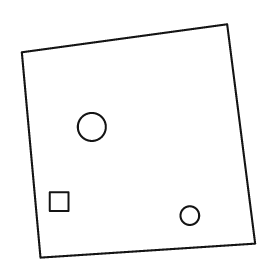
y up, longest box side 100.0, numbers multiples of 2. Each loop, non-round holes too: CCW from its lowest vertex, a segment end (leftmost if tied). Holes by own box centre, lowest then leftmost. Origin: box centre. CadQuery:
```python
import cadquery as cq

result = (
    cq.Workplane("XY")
    .moveTo(-42.0, -50.0)
    .lineTo(50.0, -44.0)
    .lineTo(38.0, 50.0)
    .lineTo(-50.0, 38.0)
    .close()
    .moveTo(22.0, -32.0)
    .circle(4.0)
    .moveTo(-38.0, -30.0)
    .lineTo(-30.0, -30.0)
    .lineTo(-30.0, -22.0)
    .lineTo(-38.0, -22.0)
    .close()
    .moveTo(-20.0, 6.0)
    .circle(6.0)
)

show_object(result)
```